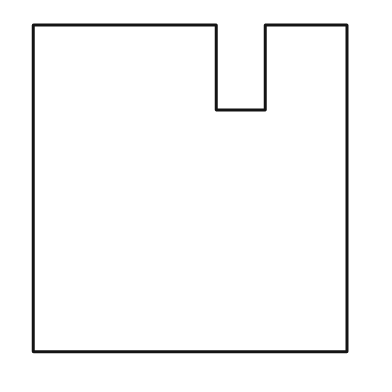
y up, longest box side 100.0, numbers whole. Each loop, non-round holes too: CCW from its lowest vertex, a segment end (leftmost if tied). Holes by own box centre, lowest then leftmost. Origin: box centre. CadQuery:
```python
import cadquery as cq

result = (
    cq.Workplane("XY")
    .moveTo(-48.0, -50.0)
    .lineTo(48.0, -50.0)
    .lineTo(48.0, 50.0)
    .lineTo(23.0, 50.0)
    .lineTo(23.0, 24.0)
    .lineTo(8.0, 24.0)
    .lineTo(8.0, 50.0)
    .lineTo(-48.0, 50.0)
    .close()
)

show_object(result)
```